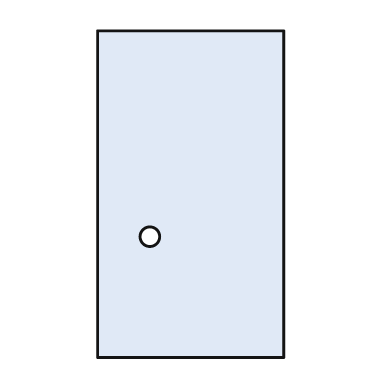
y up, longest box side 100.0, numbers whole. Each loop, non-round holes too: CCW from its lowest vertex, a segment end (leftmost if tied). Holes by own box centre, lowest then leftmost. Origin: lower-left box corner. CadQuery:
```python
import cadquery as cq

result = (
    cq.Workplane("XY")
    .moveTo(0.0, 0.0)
    .lineTo(57.0, 0.0)
    .lineTo(57.0, 100.0)
    .lineTo(0.0, 100.0)
    .close()
    .moveTo(16.0, 37.0)
    .circle(3.0)
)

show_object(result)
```